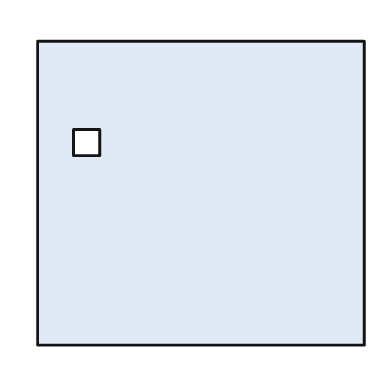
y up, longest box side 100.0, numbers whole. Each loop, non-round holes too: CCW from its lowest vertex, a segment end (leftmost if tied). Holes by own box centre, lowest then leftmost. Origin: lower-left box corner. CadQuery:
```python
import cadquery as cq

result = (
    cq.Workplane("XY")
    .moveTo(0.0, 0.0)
    .lineTo(100.0, 0.0)
    .lineTo(100.0, 93.0)
    .lineTo(0.0, 93.0)
    .close()
    .moveTo(11.0, 58.0)
    .lineTo(19.0, 58.0)
    .lineTo(19.0, 66.0)
    .lineTo(11.0, 66.0)
    .close()
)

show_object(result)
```